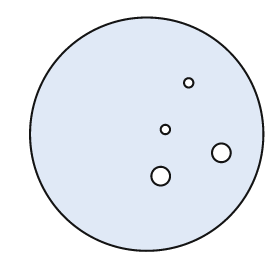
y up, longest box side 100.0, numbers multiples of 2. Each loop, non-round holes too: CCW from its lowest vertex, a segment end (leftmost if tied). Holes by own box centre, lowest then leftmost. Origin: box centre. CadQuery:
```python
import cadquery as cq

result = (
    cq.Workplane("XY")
    .moveTo(0.0, 0.0)
    .circle(50.0)
    .moveTo(6.0, -18.0)
    .circle(4.0)
    .moveTo(32.0, -8.0)
    .circle(4.0)
    .moveTo(8.0, 2.0)
    .circle(2.0)
    .moveTo(18.0, 22.0)
    .circle(2.0)
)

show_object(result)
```